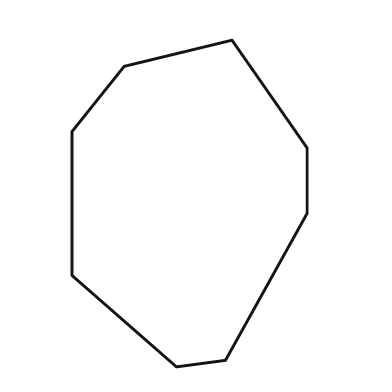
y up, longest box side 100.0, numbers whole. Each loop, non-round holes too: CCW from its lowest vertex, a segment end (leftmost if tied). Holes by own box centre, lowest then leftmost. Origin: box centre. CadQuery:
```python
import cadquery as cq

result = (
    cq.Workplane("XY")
    .moveTo(-4.0, -50.0)
    .lineTo(11.0, -48.0)
    .lineTo(36.0, -3.0)
    .lineTo(36.0, 17.0)
    .lineTo(13.0, 50.0)
    .lineTo(-20.0, 42.0)
    .lineTo(-36.0, 22.0)
    .lineTo(-36.0, -22.0)
    .close()
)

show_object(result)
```